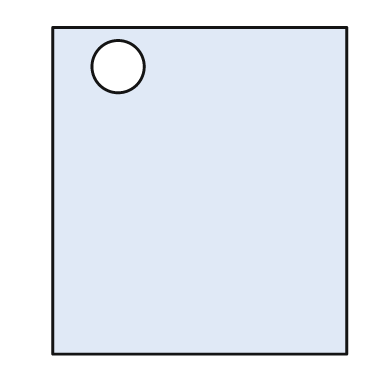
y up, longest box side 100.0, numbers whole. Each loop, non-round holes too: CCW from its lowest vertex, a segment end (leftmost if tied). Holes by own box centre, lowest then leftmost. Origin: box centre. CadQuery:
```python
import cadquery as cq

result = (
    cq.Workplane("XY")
    .moveTo(-45.0, -50.0)
    .lineTo(45.0, -50.0)
    .lineTo(45.0, 50.0)
    .lineTo(-45.0, 50.0)
    .close()
    .moveTo(-25.0, 38.0)
    .circle(8.0)
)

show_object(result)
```